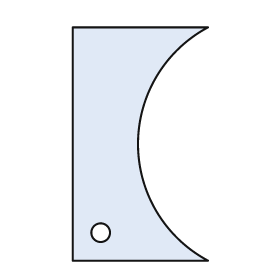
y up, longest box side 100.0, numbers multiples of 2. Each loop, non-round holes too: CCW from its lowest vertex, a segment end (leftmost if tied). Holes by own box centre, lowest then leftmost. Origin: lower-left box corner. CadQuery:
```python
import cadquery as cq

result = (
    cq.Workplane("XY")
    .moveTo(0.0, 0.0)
    .lineTo(58.0, 0.0)
    .threePointArc((28.0, 50.0), (58.0, 100.0))
    .lineTo(0.0, 100.0)
    .close()
    .moveTo(12.0, 12.0)
    .circle(4.0)
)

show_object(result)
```